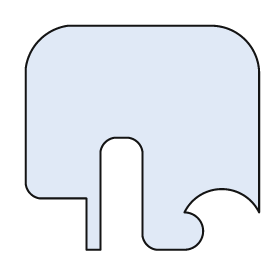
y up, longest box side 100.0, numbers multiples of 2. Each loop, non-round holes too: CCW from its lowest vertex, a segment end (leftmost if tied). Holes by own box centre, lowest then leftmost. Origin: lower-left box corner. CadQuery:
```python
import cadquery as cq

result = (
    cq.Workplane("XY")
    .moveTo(26.0, 0.0)
    .lineTo(32.0, 0.0)
    .lineTo(32.0, 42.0)
    .threePointArc((34.0, 46.0), (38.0, 48.0))
    .lineTo(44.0, 48.0)
    .threePointArc((48.0, 46.0), (50.0, 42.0))
    .lineTo(50.0, 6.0)
    .threePointArc((52.0, 2.0), (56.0, 0.0))
    .lineTo(68.0, 0.0)
    .threePointArc((76.0, 8.0), (68.0, 16.0))
    .threePointArc((84.0, 26.0), (100.0, 16.0))
    .lineTo(100.0, 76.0)
    .threePointArc((94.0, 90.0), (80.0, 96.0))
    .lineTo(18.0, 96.0)
    .threePointArc((6.0, 90.0), (0.0, 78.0))
    .lineTo(0.0, 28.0)
    .threePointArc((2.0, 24.0), (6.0, 22.0))
    .lineTo(26.0, 22.0)
    .close()
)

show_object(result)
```